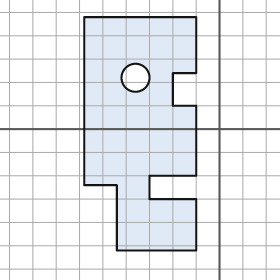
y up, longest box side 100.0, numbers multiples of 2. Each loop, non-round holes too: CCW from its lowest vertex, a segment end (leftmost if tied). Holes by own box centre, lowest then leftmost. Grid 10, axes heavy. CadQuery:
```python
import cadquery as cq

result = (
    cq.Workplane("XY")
    .moveTo(-44.0, -52.0)
    .lineTo(-10.0, -52.0)
    .lineTo(-10.0, -30.0)
    .lineTo(-30.0, -30.0)
    .lineTo(-30.0, -20.0)
    .lineTo(-10.0, -20.0)
    .lineTo(-10.0, 10.0)
    .lineTo(-20.0, 10.0)
    .lineTo(-20.0, 24.0)
    .lineTo(-10.0, 24.0)
    .lineTo(-10.0, 48.0)
    .lineTo(-58.0, 48.0)
    .lineTo(-58.0, -24.0)
    .lineTo(-44.0, -24.0)
    .close()
    .moveTo(-36.0, 22.0)
    .circle(6.0)
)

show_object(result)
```